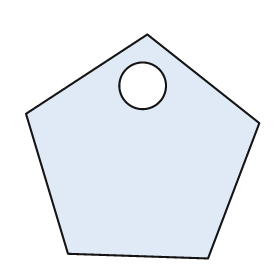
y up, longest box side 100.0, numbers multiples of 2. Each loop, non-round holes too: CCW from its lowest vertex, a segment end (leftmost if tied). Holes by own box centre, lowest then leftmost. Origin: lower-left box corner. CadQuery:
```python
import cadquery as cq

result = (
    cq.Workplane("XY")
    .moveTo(78.0, 0.0)
    .lineTo(100.0, 58.0)
    .lineTo(52.0, 96.0)
    .lineTo(0.0, 62.0)
    .lineTo(18.0, 2.0)
    .close()
    .moveTo(50.0, 74.0)
    .circle(10.0)
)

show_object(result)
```